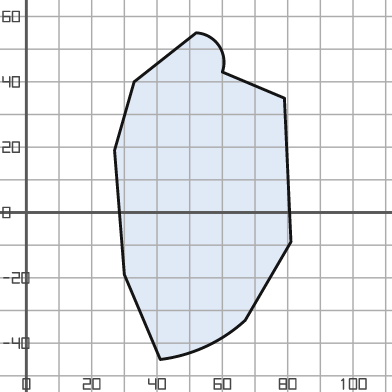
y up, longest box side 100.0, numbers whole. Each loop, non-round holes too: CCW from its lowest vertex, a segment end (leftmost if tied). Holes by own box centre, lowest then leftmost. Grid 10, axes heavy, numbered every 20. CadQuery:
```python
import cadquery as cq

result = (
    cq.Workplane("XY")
    .moveTo(41.0, -45.0)
    .threePointArc((55.0, -41.0), (67.0, -33.0))
    .lineTo(81.0, -9.0)
    .lineTo(79.0, 35.0)
    .lineTo(60.0, 43.0)
    .threePointArc((59.0, 51.0), (52.0, 55.0))
    .lineTo(33.0, 40.0)
    .lineTo(27.0, 19.0)
    .lineTo(30.0, -19.0)
    .close()
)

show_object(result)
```